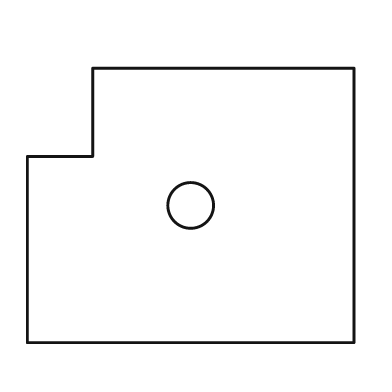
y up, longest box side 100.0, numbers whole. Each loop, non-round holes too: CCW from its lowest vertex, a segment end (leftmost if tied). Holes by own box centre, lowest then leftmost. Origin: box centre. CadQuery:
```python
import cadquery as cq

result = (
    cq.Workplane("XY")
    .moveTo(-50.0, -42.0)
    .lineTo(50.0, -42.0)
    .lineTo(50.0, 42.0)
    .lineTo(-30.0, 42.0)
    .lineTo(-30.0, 15.0)
    .lineTo(-50.0, 15.0)
    .close()
    .moveTo(0.0, 0.0)
    .circle(7.0)
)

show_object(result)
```